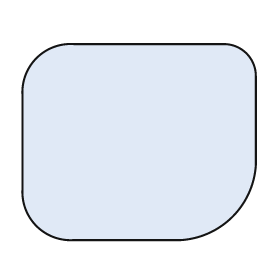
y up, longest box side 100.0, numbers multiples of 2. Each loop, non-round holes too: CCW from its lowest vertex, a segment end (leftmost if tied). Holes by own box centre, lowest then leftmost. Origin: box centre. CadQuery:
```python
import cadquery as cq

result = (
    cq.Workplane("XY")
    .moveTo(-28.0, -42.0)
    .lineTo(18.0, -42.0)
    .threePointArc((40.0, -32.0), (50.0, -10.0))
    .lineTo(50.0, 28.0)
    .threePointArc((46.0, 38.0), (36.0, 42.0))
    .lineTo(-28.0, 42.0)
    .threePointArc((-44.0, 36.0), (-50.0, 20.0))
    .lineTo(-50.0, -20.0)
    .threePointArc((-44.0, -36.0), (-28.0, -42.0))
    .close()
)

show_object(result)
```